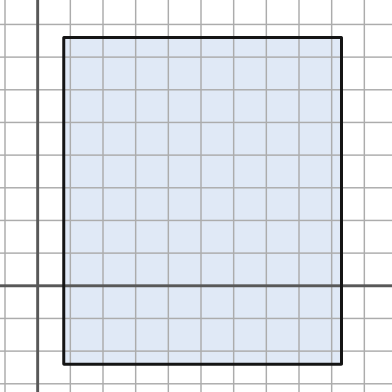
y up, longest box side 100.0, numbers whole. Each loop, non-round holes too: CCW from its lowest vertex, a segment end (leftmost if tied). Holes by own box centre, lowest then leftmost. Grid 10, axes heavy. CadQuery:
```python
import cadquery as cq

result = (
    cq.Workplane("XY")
    .moveTo(8.0, -24.0)
    .lineTo(93.0, -24.0)
    .lineTo(93.0, 76.0)
    .lineTo(8.0, 76.0)
    .close()
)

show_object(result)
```